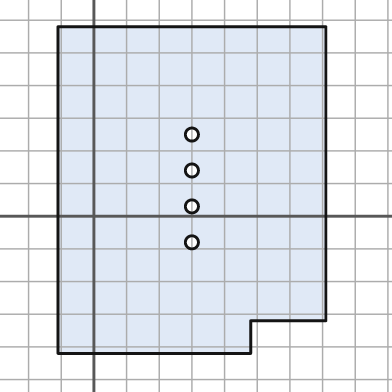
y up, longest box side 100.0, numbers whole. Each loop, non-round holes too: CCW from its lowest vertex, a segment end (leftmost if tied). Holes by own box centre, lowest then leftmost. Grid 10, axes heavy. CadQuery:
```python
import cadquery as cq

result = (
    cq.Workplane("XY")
    .moveTo(-11.0, -42.0)
    .lineTo(48.0, -42.0)
    .lineTo(48.0, -32.0)
    .lineTo(71.0, -32.0)
    .lineTo(71.0, 58.0)
    .lineTo(-11.0, 58.0)
    .close()
    .moveTo(30.0, -8.0)
    .circle(2.0)
    .moveTo(30.0, 3.0)
    .circle(2.0)
    .moveTo(30.0, 14.0)
    .circle(2.0)
    .moveTo(30.0, 25.0)
    .circle(2.0)
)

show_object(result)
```